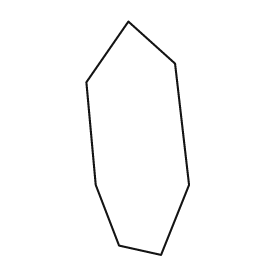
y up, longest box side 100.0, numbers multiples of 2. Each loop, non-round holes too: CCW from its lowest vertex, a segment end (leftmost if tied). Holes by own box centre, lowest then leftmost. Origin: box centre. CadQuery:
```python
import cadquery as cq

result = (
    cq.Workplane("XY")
    .moveTo(10.0, -50.0)
    .lineTo(22.0, -20.0)
    .lineTo(16.0, 32.0)
    .lineTo(-4.0, 50.0)
    .lineTo(-22.0, 24.0)
    .lineTo(-18.0, -20.0)
    .lineTo(-8.0, -46.0)
    .close()
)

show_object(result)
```